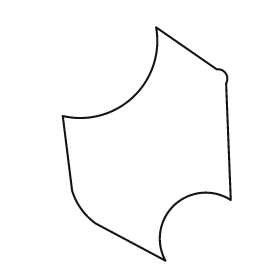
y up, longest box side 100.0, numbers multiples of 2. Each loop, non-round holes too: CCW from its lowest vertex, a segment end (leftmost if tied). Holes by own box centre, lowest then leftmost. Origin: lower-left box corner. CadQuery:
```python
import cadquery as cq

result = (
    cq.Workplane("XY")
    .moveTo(44.0, 0.0)
    .threePointArc((48.0, 24.0), (72.0, 26.0))
    .lineTo(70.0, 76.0)
    .threePointArc((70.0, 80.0), (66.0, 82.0))
    .lineTo(40.0, 100.0)
    .threePointArc((30.0, 70.0), (0.0, 62.0))
    .lineTo(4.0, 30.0)
    .threePointArc((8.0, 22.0), (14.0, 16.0))
    .close()
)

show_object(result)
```